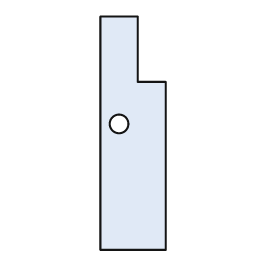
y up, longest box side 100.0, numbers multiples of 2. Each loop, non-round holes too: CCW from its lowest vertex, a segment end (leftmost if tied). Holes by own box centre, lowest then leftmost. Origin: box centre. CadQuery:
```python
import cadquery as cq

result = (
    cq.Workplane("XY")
    .moveTo(-14.0, -50.0)
    .lineTo(14.0, -50.0)
    .lineTo(14.0, 22.0)
    .lineTo(2.0, 22.0)
    .lineTo(2.0, 50.0)
    .lineTo(-14.0, 50.0)
    .close()
    .moveTo(-6.0, 4.0)
    .circle(4.0)
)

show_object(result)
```